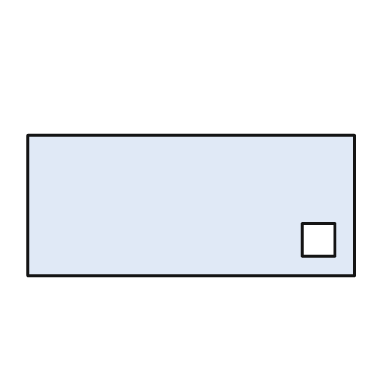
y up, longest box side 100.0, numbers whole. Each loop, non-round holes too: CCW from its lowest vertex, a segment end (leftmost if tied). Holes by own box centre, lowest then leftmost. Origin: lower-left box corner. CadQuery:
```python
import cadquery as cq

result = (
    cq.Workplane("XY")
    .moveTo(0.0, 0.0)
    .lineTo(100.0, 0.0)
    .lineTo(100.0, 43.0)
    .lineTo(0.0, 43.0)
    .close()
    .moveTo(84.0, 6.0)
    .lineTo(94.0, 6.0)
    .lineTo(94.0, 16.0)
    .lineTo(84.0, 16.0)
    .close()
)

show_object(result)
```